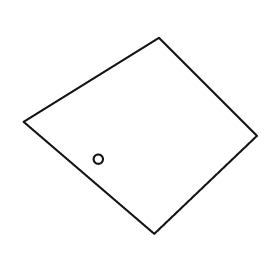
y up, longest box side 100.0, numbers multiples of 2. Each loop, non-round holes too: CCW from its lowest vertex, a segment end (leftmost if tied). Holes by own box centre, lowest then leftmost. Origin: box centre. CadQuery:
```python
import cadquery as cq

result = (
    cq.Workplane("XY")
    .moveTo(6.0, -42.0)
    .lineTo(50.0, 0.0)
    .lineTo(8.0, 42.0)
    .lineTo(-50.0, 6.0)
    .close()
    .moveTo(-18.0, -10.0)
    .circle(2.0)
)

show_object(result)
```